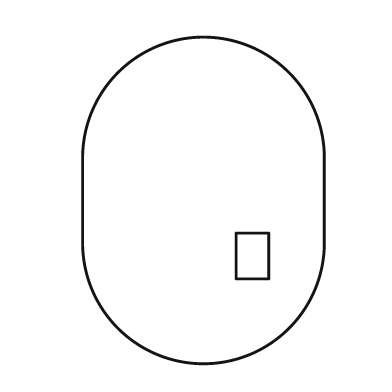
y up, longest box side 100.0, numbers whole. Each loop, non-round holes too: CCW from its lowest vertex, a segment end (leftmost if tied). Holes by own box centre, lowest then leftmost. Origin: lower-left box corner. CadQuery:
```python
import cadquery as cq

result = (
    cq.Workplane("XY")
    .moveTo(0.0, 37.0)
    .threePointArc((37.0, 0.0), (74.0, 37.0))
    .lineTo(74.0, 63.0)
    .threePointArc((37.0, 100.0), (0.0, 63.0))
    .close()
    .moveTo(47.0, 26.0)
    .lineTo(57.0, 26.0)
    .lineTo(57.0, 40.0)
    .lineTo(47.0, 40.0)
    .close()
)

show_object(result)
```